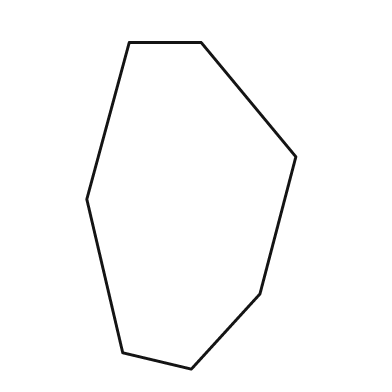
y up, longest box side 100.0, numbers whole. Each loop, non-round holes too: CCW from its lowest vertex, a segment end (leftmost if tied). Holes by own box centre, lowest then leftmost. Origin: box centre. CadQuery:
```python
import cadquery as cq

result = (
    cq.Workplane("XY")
    .moveTo(0.0, -50.0)
    .lineTo(21.0, -27.0)
    .lineTo(32.0, 15.0)
    .lineTo(3.0, 50.0)
    .lineTo(-19.0, 50.0)
    .lineTo(-32.0, 2.0)
    .lineTo(-21.0, -45.0)
    .close()
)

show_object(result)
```